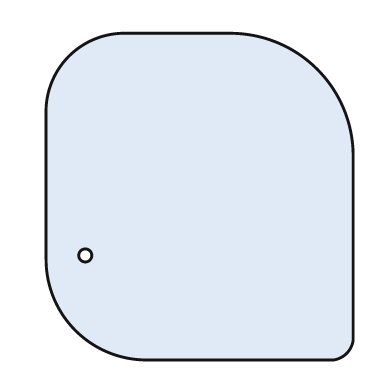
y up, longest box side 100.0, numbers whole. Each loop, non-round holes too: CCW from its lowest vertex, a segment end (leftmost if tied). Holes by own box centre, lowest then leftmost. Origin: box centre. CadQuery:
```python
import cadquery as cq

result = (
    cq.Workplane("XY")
    .moveTo(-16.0, -50.0)
    .lineTo(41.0, -50.0)
    .threePointArc((45.0, -48.0), (47.0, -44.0))
    .lineTo(47.0, 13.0)
    .threePointArc((36.0, 39.0), (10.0, 50.0))
    .lineTo(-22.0, 50.0)
    .threePointArc((-40.0, 43.0), (-47.0, 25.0))
    .lineTo(-47.0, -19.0)
    .threePointArc((-38.0, -41.0), (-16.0, -50.0))
    .close()
    .moveTo(-35.0, -18.0)
    .circle(2.0)
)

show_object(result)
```